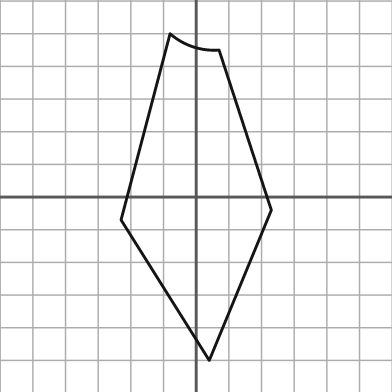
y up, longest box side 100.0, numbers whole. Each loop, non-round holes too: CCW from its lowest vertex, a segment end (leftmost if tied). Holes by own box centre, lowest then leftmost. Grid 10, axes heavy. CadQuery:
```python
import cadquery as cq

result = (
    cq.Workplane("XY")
    .moveTo(4.0, -50.0)
    .lineTo(23.0, -4.0)
    .lineTo(7.0, 45.0)
    .threePointArc((-1.0, 46.0), (-8.0, 50.0))
    .lineTo(-23.0, -7.0)
    .close()
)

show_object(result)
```